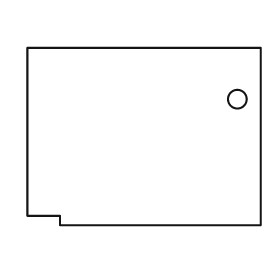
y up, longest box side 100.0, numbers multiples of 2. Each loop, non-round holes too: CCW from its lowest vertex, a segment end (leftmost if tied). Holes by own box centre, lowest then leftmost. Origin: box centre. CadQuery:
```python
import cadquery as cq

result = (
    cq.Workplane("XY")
    .moveTo(-36.0, -38.0)
    .lineTo(50.0, -38.0)
    .lineTo(50.0, 38.0)
    .lineTo(-50.0, 38.0)
    .lineTo(-50.0, -34.0)
    .lineTo(-36.0, -34.0)
    .close()
    .moveTo(40.0, 16.0)
    .circle(4.0)
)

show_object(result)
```